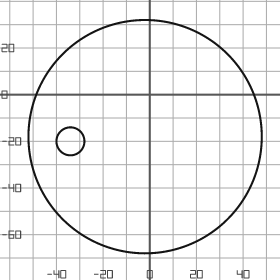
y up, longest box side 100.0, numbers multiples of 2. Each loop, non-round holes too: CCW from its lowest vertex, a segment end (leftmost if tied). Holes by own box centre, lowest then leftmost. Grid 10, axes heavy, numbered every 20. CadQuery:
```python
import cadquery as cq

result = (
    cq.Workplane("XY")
    .moveTo(-2.0, -18.0)
    .circle(50.0)
    .moveTo(-34.0, -20.0)
    .circle(6.0)
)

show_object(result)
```